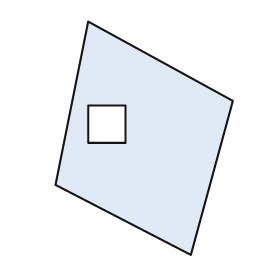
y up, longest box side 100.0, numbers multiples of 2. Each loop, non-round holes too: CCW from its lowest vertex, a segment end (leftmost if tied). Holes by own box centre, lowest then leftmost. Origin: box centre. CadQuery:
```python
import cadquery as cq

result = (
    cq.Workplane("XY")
    .moveTo(20.0, -50.0)
    .lineTo(38.0, 16.0)
    .lineTo(-24.0, 50.0)
    .lineTo(-38.0, -20.0)
    .close()
    .moveTo(-24.0, -2.0)
    .lineTo(-8.0, -2.0)
    .lineTo(-8.0, 14.0)
    .lineTo(-24.0, 14.0)
    .close()
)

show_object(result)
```